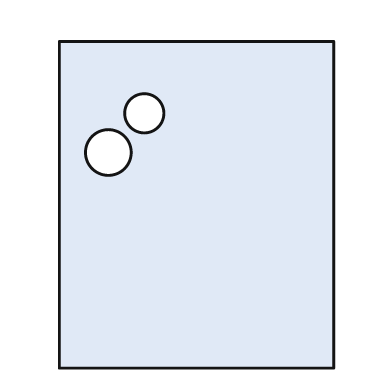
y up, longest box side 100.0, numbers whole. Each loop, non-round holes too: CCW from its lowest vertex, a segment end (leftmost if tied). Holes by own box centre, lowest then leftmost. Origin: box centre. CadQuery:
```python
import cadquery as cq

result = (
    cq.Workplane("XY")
    .moveTo(-42.0, -50.0)
    .lineTo(42.0, -50.0)
    .lineTo(42.0, 50.0)
    .lineTo(-42.0, 50.0)
    .close()
    .moveTo(-27.0, 16.0)
    .circle(7.0)
    .moveTo(-16.0, 28.0)
    .circle(6.0)
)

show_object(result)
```